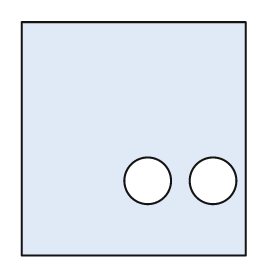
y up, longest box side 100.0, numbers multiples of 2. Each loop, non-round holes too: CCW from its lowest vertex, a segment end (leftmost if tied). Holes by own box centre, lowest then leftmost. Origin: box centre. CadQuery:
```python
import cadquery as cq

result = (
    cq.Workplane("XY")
    .moveTo(-48.0, -50.0)
    .lineTo(48.0, -50.0)
    .lineTo(48.0, 50.0)
    .lineTo(-48.0, 50.0)
    .close()
    .moveTo(6.0, -18.0)
    .circle(10.0)
    .moveTo(34.0, -18.0)
    .circle(10.0)
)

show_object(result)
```